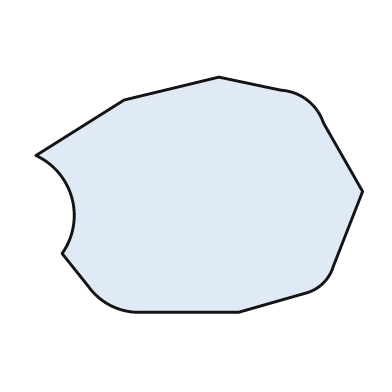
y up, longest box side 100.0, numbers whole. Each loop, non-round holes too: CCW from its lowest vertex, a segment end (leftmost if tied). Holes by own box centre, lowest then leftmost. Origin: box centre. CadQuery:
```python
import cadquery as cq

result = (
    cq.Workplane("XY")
    .moveTo(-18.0, -36.0)
    .lineTo(12.0, -36.0)
    .lineTo(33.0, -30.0)
    .threePointArc((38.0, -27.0), (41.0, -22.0))
    .lineTo(50.0, 1.0)
    .lineTo(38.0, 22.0)
    .threePointArc((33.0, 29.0), (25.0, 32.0))
    .lineTo(6.0, 36.0)
    .lineTo(-23.0, 29.0)
    .lineTo(-50.0, 12.0)
    .threePointArc((-39.0, -1.0), (-42.0, -18.0))
    .lineTo(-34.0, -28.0)
    .threePointArc((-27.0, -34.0), (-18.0, -36.0))
    .close()
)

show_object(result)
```